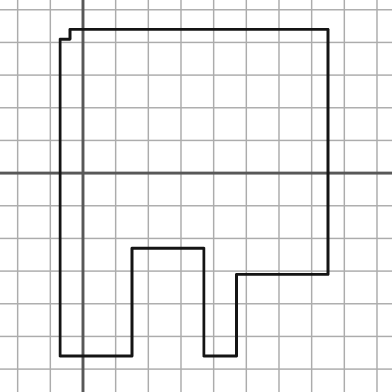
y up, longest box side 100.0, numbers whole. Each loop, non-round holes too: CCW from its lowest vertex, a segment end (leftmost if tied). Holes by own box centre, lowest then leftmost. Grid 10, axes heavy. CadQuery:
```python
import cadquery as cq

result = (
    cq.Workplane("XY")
    .moveTo(-7.0, -56.0)
    .lineTo(15.0, -56.0)
    .lineTo(15.0, -23.0)
    .lineTo(37.0, -23.0)
    .lineTo(37.0, -56.0)
    .lineTo(47.0, -56.0)
    .lineTo(47.0, -31.0)
    .lineTo(75.0, -31.0)
    .lineTo(75.0, 44.0)
    .lineTo(-4.0, 44.0)
    .lineTo(-4.0, 41.0)
    .lineTo(-7.0, 41.0)
    .close()
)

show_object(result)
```